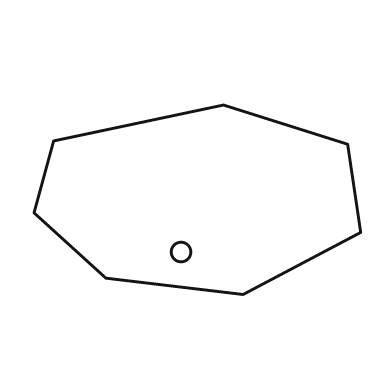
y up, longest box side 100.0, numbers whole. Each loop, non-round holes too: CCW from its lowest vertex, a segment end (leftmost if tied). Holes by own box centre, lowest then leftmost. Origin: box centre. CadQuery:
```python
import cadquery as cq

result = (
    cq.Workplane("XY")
    .moveTo(14.0, -29.0)
    .lineTo(50.0, -10.0)
    .lineTo(46.0, 17.0)
    .lineTo(8.0, 29.0)
    .lineTo(-44.0, 18.0)
    .lineTo(-50.0, -4.0)
    .lineTo(-28.0, -24.0)
    .close()
    .moveTo(-5.0, -16.0)
    .circle(3.0)
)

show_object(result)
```